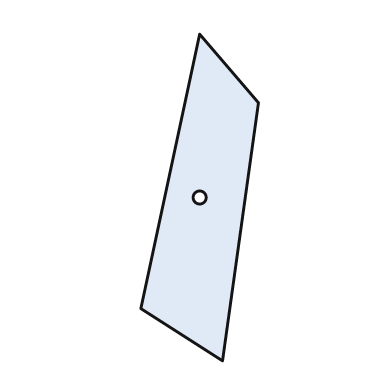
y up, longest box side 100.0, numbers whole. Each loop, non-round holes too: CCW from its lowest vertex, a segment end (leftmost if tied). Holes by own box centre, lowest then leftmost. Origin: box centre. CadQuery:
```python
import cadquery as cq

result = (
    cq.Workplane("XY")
    .moveTo(7.0, -50.0)
    .lineTo(18.0, 29.0)
    .lineTo(0.0, 50.0)
    .lineTo(-18.0, -34.0)
    .close()
    .moveTo(0.0, 0.0)
    .circle(2.0)
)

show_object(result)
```